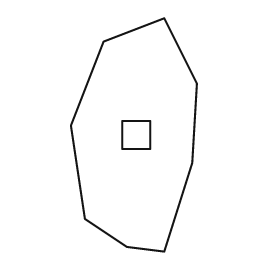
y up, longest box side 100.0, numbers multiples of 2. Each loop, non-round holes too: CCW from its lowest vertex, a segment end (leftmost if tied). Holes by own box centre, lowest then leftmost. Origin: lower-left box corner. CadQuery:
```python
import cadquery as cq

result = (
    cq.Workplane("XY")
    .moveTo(40.0, 0.0)
    .lineTo(52.0, 38.0)
    .lineTo(54.0, 72.0)
    .lineTo(40.0, 100.0)
    .lineTo(14.0, 90.0)
    .lineTo(0.0, 54.0)
    .lineTo(6.0, 14.0)
    .lineTo(24.0, 2.0)
    .close()
    .moveTo(22.0, 44.0)
    .lineTo(34.0, 44.0)
    .lineTo(34.0, 56.0)
    .lineTo(22.0, 56.0)
    .close()
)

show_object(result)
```